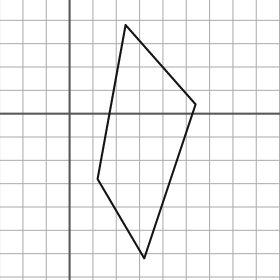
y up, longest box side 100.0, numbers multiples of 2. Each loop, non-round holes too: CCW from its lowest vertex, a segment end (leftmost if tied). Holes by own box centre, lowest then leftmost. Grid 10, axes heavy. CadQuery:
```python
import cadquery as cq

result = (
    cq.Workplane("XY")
    .moveTo(32.0, -62.0)
    .lineTo(54.0, 4.0)
    .lineTo(24.0, 38.0)
    .lineTo(12.0, -28.0)
    .close()
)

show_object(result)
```